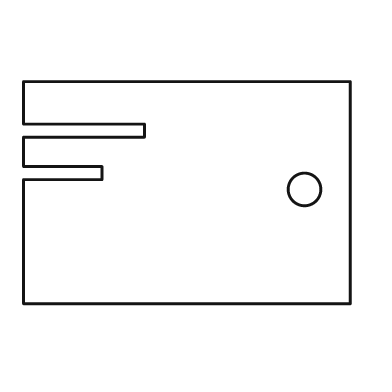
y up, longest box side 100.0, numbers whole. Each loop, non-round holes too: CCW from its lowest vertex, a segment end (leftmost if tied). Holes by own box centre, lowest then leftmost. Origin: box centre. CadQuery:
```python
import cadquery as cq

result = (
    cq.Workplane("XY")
    .moveTo(-50.0, -34.0)
    .lineTo(50.0, -34.0)
    .lineTo(50.0, 34.0)
    .lineTo(-50.0, 34.0)
    .lineTo(-50.0, 21.0)
    .lineTo(-13.0, 21.0)
    .lineTo(-13.0, 17.0)
    .lineTo(-50.0, 17.0)
    .lineTo(-50.0, 8.0)
    .lineTo(-26.0, 8.0)
    .lineTo(-26.0, 4.0)
    .lineTo(-50.0, 4.0)
    .close()
    .moveTo(36.0, 1.0)
    .circle(5.0)
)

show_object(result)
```